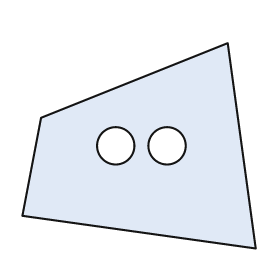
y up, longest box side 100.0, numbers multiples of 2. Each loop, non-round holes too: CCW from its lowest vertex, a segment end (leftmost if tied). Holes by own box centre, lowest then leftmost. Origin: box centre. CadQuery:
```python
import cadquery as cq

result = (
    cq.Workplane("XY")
    .moveTo(50.0, -44.0)
    .lineTo(38.0, 44.0)
    .lineTo(-42.0, 12.0)
    .lineTo(-50.0, -30.0)
    .close()
    .moveTo(-10.0, 0.0)
    .circle(8.0)
    .moveTo(12.0, 0.0)
    .circle(8.0)
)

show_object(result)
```